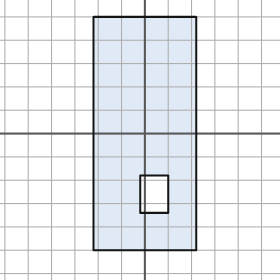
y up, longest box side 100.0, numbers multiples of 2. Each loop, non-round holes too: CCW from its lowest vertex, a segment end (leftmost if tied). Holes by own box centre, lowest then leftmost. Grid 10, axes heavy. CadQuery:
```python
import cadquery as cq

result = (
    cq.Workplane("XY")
    .moveTo(-22.0, -50.0)
    .lineTo(22.0, -50.0)
    .lineTo(22.0, 50.0)
    .lineTo(-22.0, 50.0)
    .close()
    .moveTo(-2.0, -34.0)
    .lineTo(10.0, -34.0)
    .lineTo(10.0, -18.0)
    .lineTo(-2.0, -18.0)
    .close()
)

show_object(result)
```